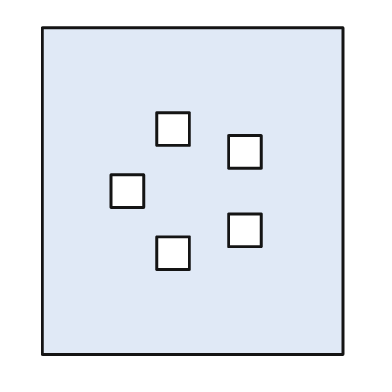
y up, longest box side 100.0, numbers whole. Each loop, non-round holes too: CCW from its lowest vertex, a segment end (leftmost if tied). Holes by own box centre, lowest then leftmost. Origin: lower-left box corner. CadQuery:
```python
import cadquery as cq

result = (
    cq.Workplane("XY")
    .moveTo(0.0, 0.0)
    .lineTo(92.0, 0.0)
    .lineTo(92.0, 100.0)
    .lineTo(0.0, 100.0)
    .close()
    .moveTo(35.0, 26.0)
    .lineTo(45.0, 26.0)
    .lineTo(45.0, 36.0)
    .lineTo(35.0, 36.0)
    .close()
    .moveTo(57.0, 33.0)
    .lineTo(67.0, 33.0)
    .lineTo(67.0, 43.0)
    .lineTo(57.0, 43.0)
    .close()
    .moveTo(21.0, 45.0)
    .lineTo(31.0, 45.0)
    .lineTo(31.0, 55.0)
    .lineTo(21.0, 55.0)
    .close()
    .moveTo(57.0, 57.0)
    .lineTo(67.0, 57.0)
    .lineTo(67.0, 67.0)
    .lineTo(57.0, 67.0)
    .close()
    .moveTo(35.0, 64.0)
    .lineTo(45.0, 64.0)
    .lineTo(45.0, 74.0)
    .lineTo(35.0, 74.0)
    .close()
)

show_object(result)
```